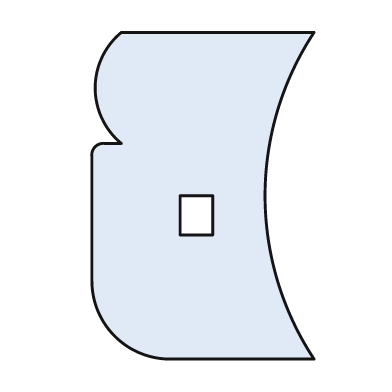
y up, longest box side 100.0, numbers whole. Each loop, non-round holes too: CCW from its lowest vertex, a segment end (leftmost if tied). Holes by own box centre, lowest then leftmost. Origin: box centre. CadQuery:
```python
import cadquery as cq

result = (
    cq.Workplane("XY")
    .moveTo(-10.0, -50.0)
    .lineTo(34.0, -50.0)
    .threePointArc((19.0, 0.0), (34.0, 50.0))
    .lineTo(-25.0, 50.0)
    .threePointArc((-33.0, 33.0), (-25.0, 16.0))
    .lineTo(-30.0, 16.0)
    .threePointArc((-33.0, 15.0), (-34.0, 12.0))
    .lineTo(-34.0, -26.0)
    .threePointArc((-27.0, -43.0), (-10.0, -50.0))
    .close()
    .moveTo(-7.0, -12.0)
    .lineTo(3.0, -12.0)
    .lineTo(3.0, 0.0)
    .lineTo(-7.0, 0.0)
    .close()
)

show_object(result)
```